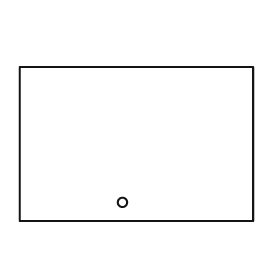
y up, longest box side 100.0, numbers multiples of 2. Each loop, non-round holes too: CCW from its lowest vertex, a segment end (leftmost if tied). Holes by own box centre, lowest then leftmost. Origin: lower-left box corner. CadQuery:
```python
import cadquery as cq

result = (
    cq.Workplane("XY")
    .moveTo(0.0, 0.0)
    .lineTo(100.0, 0.0)
    .lineTo(100.0, 66.0)
    .lineTo(0.0, 66.0)
    .close()
    .moveTo(44.0, 8.0)
    .circle(2.0)
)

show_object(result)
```